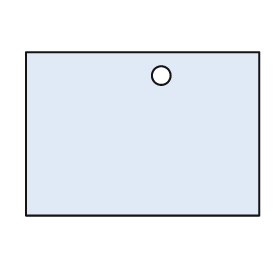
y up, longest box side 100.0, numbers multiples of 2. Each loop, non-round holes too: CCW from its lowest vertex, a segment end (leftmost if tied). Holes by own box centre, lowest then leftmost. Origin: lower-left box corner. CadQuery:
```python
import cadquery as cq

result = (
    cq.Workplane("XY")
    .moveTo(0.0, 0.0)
    .lineTo(100.0, 0.0)
    .lineTo(100.0, 70.0)
    .lineTo(0.0, 70.0)
    .close()
    .moveTo(58.0, 60.0)
    .circle(4.0)
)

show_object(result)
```